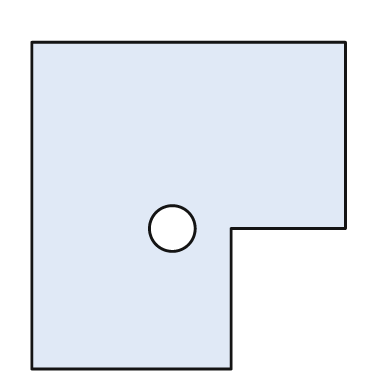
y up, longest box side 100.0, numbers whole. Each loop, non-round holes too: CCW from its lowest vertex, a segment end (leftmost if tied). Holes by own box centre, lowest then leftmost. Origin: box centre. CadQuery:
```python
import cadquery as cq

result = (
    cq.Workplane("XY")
    .moveTo(-48.0, -50.0)
    .lineTo(13.0, -50.0)
    .lineTo(13.0, -7.0)
    .lineTo(48.0, -7.0)
    .lineTo(48.0, 50.0)
    .lineTo(-48.0, 50.0)
    .close()
    .moveTo(-5.0, -7.0)
    .circle(7.0)
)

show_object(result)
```